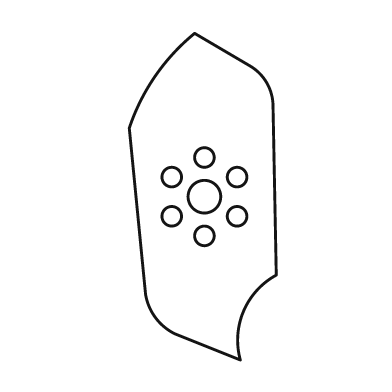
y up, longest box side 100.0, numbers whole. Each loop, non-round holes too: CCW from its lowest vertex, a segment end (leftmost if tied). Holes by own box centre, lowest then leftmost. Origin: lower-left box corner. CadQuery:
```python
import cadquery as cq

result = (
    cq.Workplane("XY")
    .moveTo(34.0, 0.0)
    .threePointArc((35.0, 15.0), (45.0, 26.0))
    .lineTo(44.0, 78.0)
    .threePointArc((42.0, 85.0), (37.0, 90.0))
    .lineTo(20.0, 100.0)
    .threePointArc((8.0, 87.0), (0.0, 71.0))
    .lineTo(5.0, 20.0)
    .threePointArc((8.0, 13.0), (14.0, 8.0))
    .close()
    .moveTo(23.0, 38.0)
    .circle(3.0)
    .moveTo(13.0, 44.0)
    .circle(3.0)
    .moveTo(33.0, 44.0)
    .circle(3.0)
    .moveTo(23.0, 50.0)
    .circle(5.0)
    .moveTo(13.0, 56.0)
    .circle(3.0)
    .moveTo(33.0, 56.0)
    .circle(3.0)
    .moveTo(23.0, 62.0)
    .circle(3.0)
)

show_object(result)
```